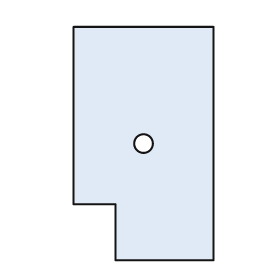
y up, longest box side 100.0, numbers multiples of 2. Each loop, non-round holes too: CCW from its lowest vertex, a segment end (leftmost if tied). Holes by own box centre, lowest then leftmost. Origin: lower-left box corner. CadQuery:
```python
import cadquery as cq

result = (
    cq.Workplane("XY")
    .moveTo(18.0, 0.0)
    .lineTo(60.0, 0.0)
    .lineTo(60.0, 100.0)
    .lineTo(0.0, 100.0)
    .lineTo(0.0, 24.0)
    .lineTo(18.0, 24.0)
    .close()
    .moveTo(30.0, 50.0)
    .circle(4.0)
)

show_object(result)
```